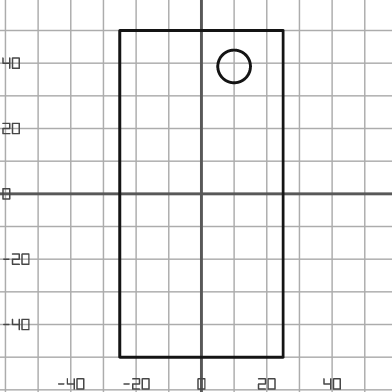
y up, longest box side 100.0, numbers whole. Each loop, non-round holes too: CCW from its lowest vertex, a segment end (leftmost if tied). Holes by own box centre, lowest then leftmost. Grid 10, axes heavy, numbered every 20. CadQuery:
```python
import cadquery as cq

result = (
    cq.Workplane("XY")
    .moveTo(-25.0, -50.0)
    .lineTo(25.0, -50.0)
    .lineTo(25.0, 50.0)
    .lineTo(-25.0, 50.0)
    .close()
    .moveTo(10.0, 39.0)
    .circle(5.0)
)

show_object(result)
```